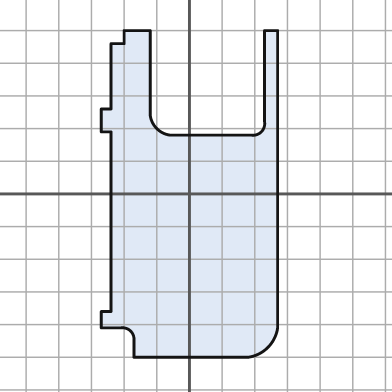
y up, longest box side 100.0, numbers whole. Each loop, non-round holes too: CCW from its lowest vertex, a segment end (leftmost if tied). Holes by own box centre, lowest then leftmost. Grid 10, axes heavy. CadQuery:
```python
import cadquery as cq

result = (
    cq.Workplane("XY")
    .moveTo(-17.0, -50.0)
    .lineTo(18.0, -50.0)
    .threePointArc((24.0, -47.0), (27.0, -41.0))
    .lineTo(27.0, 50.0)
    .lineTo(23.0, 50.0)
    .lineTo(23.0, 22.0)
    .threePointArc((22.0, 19.0), (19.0, 18.0))
    .lineTo(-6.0, 18.0)
    .threePointArc((-10.0, 20.0), (-12.0, 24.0))
    .lineTo(-12.0, 50.0)
    .lineTo(-20.0, 50.0)
    .lineTo(-20.0, 46.0)
    .lineTo(-24.0, 46.0)
    .lineTo(-24.0, 26.0)
    .lineTo(-27.0, 26.0)
    .lineTo(-27.0, 19.0)
    .lineTo(-24.0, 19.0)
    .lineTo(-24.0, -36.0)
    .lineTo(-27.0, -36.0)
    .lineTo(-27.0, -41.0)
    .lineTo(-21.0, -41.0)
    .threePointArc((-18.0, -42.0), (-17.0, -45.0))
    .close()
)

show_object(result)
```